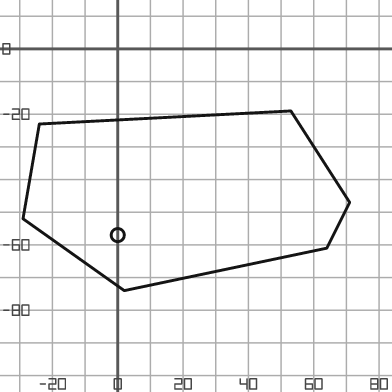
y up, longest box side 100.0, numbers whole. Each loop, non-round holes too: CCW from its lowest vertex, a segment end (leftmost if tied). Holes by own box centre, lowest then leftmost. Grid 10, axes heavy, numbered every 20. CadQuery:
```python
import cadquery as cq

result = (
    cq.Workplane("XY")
    .moveTo(2.0, -74.0)
    .lineTo(64.0, -61.0)
    .lineTo(71.0, -47.0)
    .lineTo(53.0, -19.0)
    .lineTo(-24.0, -23.0)
    .lineTo(-29.0, -52.0)
    .close()
    .moveTo(0.0, -57.0)
    .circle(2.0)
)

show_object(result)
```